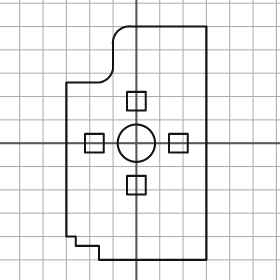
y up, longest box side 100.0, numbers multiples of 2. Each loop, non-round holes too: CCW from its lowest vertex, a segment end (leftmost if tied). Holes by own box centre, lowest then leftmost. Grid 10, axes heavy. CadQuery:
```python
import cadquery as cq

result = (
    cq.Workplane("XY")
    .moveTo(-16.0, -50.0)
    .lineTo(30.0, -50.0)
    .lineTo(30.0, 50.0)
    .lineTo(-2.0, 50.0)
    .threePointArc((-8.0, 48.0), (-10.0, 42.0))
    .lineTo(-10.0, 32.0)
    .threePointArc((-12.0, 28.0), (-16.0, 26.0))
    .lineTo(-30.0, 26.0)
    .lineTo(-30.0, -40.0)
    .lineTo(-26.0, -40.0)
    .lineTo(-26.0, -44.0)
    .lineTo(-16.0, -44.0)
    .close()
    .moveTo(-4.0, -22.0)
    .lineTo(4.0, -22.0)
    .lineTo(4.0, -14.0)
    .lineTo(-4.0, -14.0)
    .close()
    .moveTo(-22.0, -4.0)
    .lineTo(-14.0, -4.0)
    .lineTo(-14.0, 4.0)
    .lineTo(-22.0, 4.0)
    .close()
    .moveTo(0.0, 0.0)
    .circle(8.0)
    .moveTo(14.0, -4.0)
    .lineTo(22.0, -4.0)
    .lineTo(22.0, 4.0)
    .lineTo(14.0, 4.0)
    .close()
    .moveTo(-4.0, 14.0)
    .lineTo(4.0, 14.0)
    .lineTo(4.0, 22.0)
    .lineTo(-4.0, 22.0)
    .close()
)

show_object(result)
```